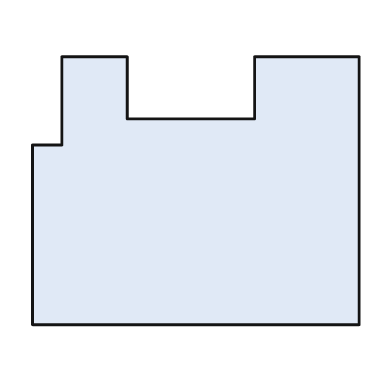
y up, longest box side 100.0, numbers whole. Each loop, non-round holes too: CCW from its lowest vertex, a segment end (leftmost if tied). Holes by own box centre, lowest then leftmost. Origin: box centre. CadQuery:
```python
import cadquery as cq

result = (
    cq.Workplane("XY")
    .moveTo(-50.0, -41.0)
    .lineTo(50.0, -41.0)
    .lineTo(50.0, 41.0)
    .lineTo(18.0, 41.0)
    .lineTo(18.0, 22.0)
    .lineTo(-21.0, 22.0)
    .lineTo(-21.0, 41.0)
    .lineTo(-41.0, 41.0)
    .lineTo(-41.0, 14.0)
    .lineTo(-50.0, 14.0)
    .close()
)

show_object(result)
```